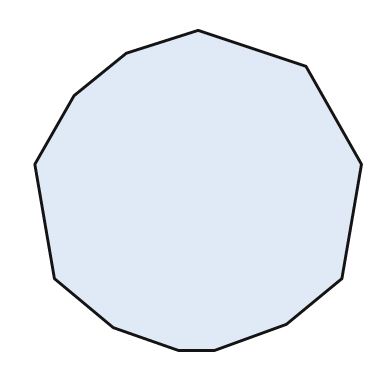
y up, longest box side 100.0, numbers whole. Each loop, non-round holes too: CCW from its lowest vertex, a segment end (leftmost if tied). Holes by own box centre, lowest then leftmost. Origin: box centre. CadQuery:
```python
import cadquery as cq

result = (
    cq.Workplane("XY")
    .moveTo(-6.0, -49.0)
    .lineTo(5.0, -49.0)
    .lineTo(27.0, -41.0)
    .lineTo(44.0, -27.0)
    .lineTo(50.0, 8.0)
    .lineTo(33.0, 38.0)
    .lineTo(0.0, 49.0)
    .lineTo(-22.0, 42.0)
    .lineTo(-38.0, 29.0)
    .lineTo(-50.0, 8.0)
    .lineTo(-44.0, -27.0)
    .lineTo(-26.0, -42.0)
    .close()
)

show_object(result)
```